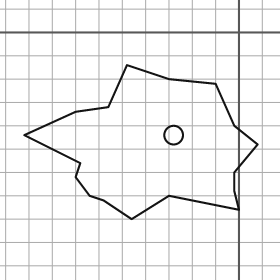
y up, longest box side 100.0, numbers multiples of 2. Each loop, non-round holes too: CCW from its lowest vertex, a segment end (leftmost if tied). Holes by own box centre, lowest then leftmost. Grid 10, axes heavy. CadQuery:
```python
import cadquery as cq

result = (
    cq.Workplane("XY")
    .moveTo(-46.0, -80.0)
    .lineTo(-30.0, -70.0)
    .lineTo(0.0, -76.0)
    .lineTo(-2.0, -68.0)
    .lineTo(-2.0, -60.0)
    .lineTo(8.0, -48.0)
    .lineTo(-2.0, -40.0)
    .lineTo(-10.0, -22.0)
    .lineTo(-30.0, -20.0)
    .lineTo(-48.0, -14.0)
    .lineTo(-56.0, -32.0)
    .lineTo(-70.0, -34.0)
    .lineTo(-92.0, -44.0)
    .lineTo(-68.0, -56.0)
    .lineTo(-70.0, -62.0)
    .lineTo(-64.0, -70.0)
    .lineTo(-58.0, -72.0)
    .close()
    .moveTo(-28.0, -44.0)
    .circle(4.0)
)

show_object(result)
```